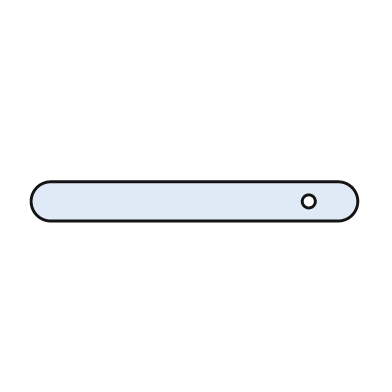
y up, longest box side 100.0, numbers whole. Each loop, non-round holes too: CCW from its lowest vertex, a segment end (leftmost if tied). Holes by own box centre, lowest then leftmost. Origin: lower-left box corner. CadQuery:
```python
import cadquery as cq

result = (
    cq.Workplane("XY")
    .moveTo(6.0, 0.0)
    .lineTo(94.0, 0.0)
    .threePointArc((100.0, 6.0), (94.0, 12.0))
    .lineTo(6.0, 12.0)
    .threePointArc((0.0, 6.0), (6.0, 0.0))
    .close()
    .moveTo(85.0, 6.0)
    .circle(2.0)
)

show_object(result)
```